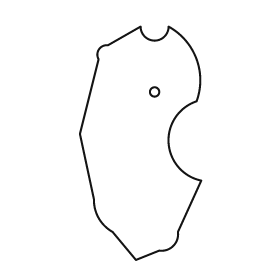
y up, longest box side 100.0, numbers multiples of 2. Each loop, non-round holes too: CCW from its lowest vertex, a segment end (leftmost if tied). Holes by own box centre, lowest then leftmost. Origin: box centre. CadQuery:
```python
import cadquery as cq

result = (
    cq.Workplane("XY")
    .moveTo(-2.0, -50.0)
    .lineTo(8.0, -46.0)
    .threePointArc((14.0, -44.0), (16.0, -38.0))
    .lineTo(26.0, -16.0)
    .threePointArc((12.0, 0.0), (24.0, 18.0))
    .threePointArc((24.0, 36.0), (12.0, 50.0))
    .threePointArc((6.0, 44.0), (0.0, 50.0))
    .lineTo(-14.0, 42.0)
    .threePointArc((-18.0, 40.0), (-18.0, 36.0))
    .lineTo(-26.0, 4.0)
    .lineTo(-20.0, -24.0)
    .threePointArc((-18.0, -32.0), (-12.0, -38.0))
    .close()
    .moveTo(6.0, 22.0)
    .circle(2.0)
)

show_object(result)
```